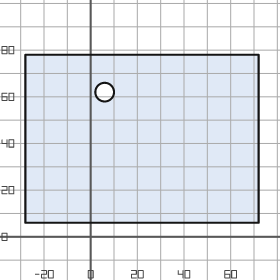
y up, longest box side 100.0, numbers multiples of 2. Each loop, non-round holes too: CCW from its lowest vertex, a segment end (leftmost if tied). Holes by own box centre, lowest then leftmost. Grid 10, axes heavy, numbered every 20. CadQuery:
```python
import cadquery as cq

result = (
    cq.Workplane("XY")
    .moveTo(-28.0, 6.0)
    .lineTo(72.0, 6.0)
    .lineTo(72.0, 78.0)
    .lineTo(-28.0, 78.0)
    .close()
    .moveTo(6.0, 62.0)
    .circle(4.0)
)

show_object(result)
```